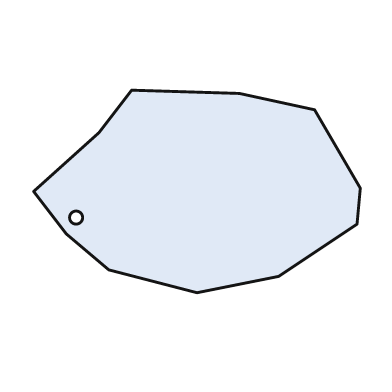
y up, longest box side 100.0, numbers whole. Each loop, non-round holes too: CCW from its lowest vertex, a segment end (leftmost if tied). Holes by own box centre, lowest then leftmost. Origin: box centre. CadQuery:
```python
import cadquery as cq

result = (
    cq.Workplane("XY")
    .moveTo(0.0, -31.0)
    .lineTo(25.0, -26.0)
    .lineTo(49.0, -10.0)
    .lineTo(50.0, 1.0)
    .lineTo(36.0, 25.0)
    .lineTo(13.0, 30.0)
    .lineTo(-20.0, 31.0)
    .lineTo(-30.0, 18.0)
    .lineTo(-50.0, 0.0)
    .lineTo(-40.0, -13.0)
    .lineTo(-27.0, -24.0)
    .close()
    .moveTo(-37.0, -8.0)
    .circle(2.0)
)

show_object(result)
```